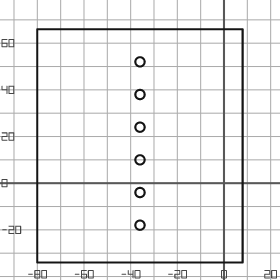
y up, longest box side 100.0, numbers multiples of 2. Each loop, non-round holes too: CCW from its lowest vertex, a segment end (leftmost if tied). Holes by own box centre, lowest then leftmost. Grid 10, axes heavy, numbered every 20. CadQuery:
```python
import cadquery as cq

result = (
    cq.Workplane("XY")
    .moveTo(-80.0, -34.0)
    .lineTo(8.0, -34.0)
    .lineTo(8.0, 66.0)
    .lineTo(-80.0, 66.0)
    .close()
    .moveTo(-36.0, -18.0)
    .circle(2.0)
    .moveTo(-36.0, -4.0)
    .circle(2.0)
    .moveTo(-36.0, 10.0)
    .circle(2.0)
    .moveTo(-36.0, 24.0)
    .circle(2.0)
    .moveTo(-36.0, 38.0)
    .circle(2.0)
    .moveTo(-36.0, 52.0)
    .circle(2.0)
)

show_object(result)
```